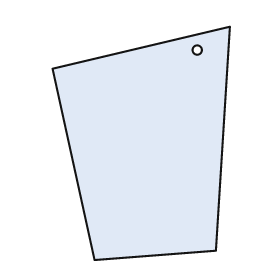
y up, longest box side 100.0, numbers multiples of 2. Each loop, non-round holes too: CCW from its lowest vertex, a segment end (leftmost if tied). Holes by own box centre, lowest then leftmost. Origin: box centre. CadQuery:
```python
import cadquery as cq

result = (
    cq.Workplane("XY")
    .moveTo(-20.0, -50.0)
    .lineTo(32.0, -46.0)
    .lineTo(38.0, 50.0)
    .lineTo(-38.0, 32.0)
    .close()
    .moveTo(24.0, 40.0)
    .circle(2.0)
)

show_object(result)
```